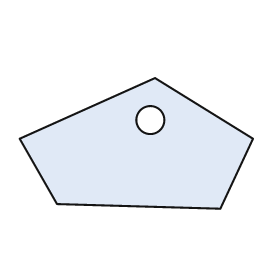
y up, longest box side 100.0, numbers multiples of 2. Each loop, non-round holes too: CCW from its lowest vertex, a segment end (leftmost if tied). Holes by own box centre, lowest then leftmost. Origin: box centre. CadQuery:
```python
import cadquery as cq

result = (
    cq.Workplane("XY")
    .moveTo(36.0, -28.0)
    .lineTo(50.0, 2.0)
    .lineTo(8.0, 28.0)
    .lineTo(-50.0, 2.0)
    .lineTo(-34.0, -26.0)
    .close()
    .moveTo(6.0, 10.0)
    .circle(6.0)
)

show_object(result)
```